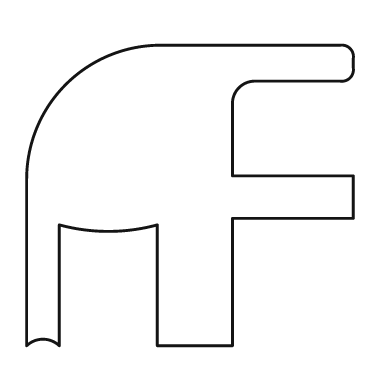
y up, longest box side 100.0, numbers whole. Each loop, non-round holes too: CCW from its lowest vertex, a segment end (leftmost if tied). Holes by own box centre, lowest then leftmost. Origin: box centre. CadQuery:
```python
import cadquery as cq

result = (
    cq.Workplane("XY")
    .moveTo(-50.0, -46.0)
    .threePointArc((-45.0, -44.0), (-40.0, -46.0))
    .lineTo(-40.0, -9.0)
    .threePointArc((-25.0, -11.0), (-10.0, -9.0))
    .lineTo(-10.0, -46.0)
    .lineTo(13.0, -46.0)
    .lineTo(13.0, -7.0)
    .lineTo(50.0, -7.0)
    .lineTo(50.0, 6.0)
    .lineTo(13.0, 6.0)
    .lineTo(13.0, 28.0)
    .threePointArc((15.0, 33.0), (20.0, 35.0))
    .lineTo(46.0, 35.0)
    .threePointArc((49.0, 36.0), (50.0, 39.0))
    .lineTo(50.0, 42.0)
    .threePointArc((49.0, 45.0), (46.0, 46.0))
    .lineTo(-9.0, 46.0)
    .threePointArc((-38.0, 34.0), (-50.0, 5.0))
    .close()
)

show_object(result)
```